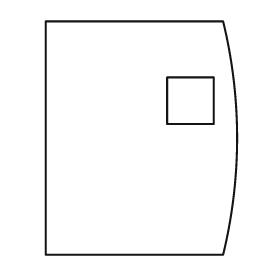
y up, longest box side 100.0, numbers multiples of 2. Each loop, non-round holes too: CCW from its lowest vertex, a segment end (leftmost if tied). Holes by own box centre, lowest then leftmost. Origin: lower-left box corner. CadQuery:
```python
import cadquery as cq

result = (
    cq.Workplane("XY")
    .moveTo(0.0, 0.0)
    .lineTo(76.0, 0.0)
    .threePointArc((82.0, 50.0), (76.0, 100.0))
    .lineTo(0.0, 100.0)
    .close()
    .moveTo(52.0, 56.0)
    .lineTo(72.0, 56.0)
    .lineTo(72.0, 76.0)
    .lineTo(52.0, 76.0)
    .close()
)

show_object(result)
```